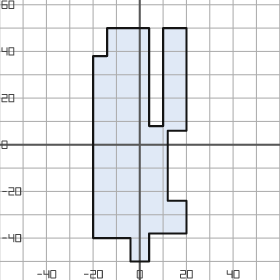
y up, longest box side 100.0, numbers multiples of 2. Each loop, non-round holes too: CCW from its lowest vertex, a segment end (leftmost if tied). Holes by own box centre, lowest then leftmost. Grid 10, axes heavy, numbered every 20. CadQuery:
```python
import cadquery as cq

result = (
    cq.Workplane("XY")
    .moveTo(-4.0, -50.0)
    .lineTo(4.0, -50.0)
    .lineTo(4.0, -38.0)
    .lineTo(20.0, -38.0)
    .lineTo(20.0, -24.0)
    .lineTo(12.0, -24.0)
    .lineTo(12.0, 6.0)
    .lineTo(20.0, 6.0)
    .lineTo(20.0, 50.0)
    .lineTo(10.0, 50.0)
    .lineTo(10.0, 8.0)
    .lineTo(4.0, 8.0)
    .lineTo(4.0, 50.0)
    .lineTo(-14.0, 50.0)
    .lineTo(-14.0, 38.0)
    .lineTo(-20.0, 38.0)
    .lineTo(-20.0, -40.0)
    .lineTo(-4.0, -40.0)
    .close()
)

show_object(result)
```